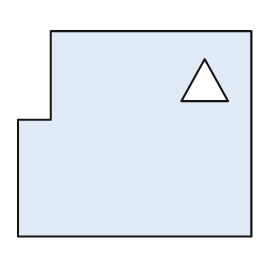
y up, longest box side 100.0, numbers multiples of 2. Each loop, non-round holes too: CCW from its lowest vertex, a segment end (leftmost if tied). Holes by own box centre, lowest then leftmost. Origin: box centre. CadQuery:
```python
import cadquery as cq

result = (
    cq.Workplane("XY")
    .moveTo(-50.0, -44.0)
    .lineTo(50.0, -44.0)
    .lineTo(50.0, 44.0)
    .lineTo(-36.0, 44.0)
    .lineTo(-36.0, 6.0)
    .lineTo(-50.0, 6.0)
    .close()
    .moveTo(20.0, 14.0)
    .lineTo(40.0, 14.0)
    .lineTo(30.0, 32.0)
    .close()
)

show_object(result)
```